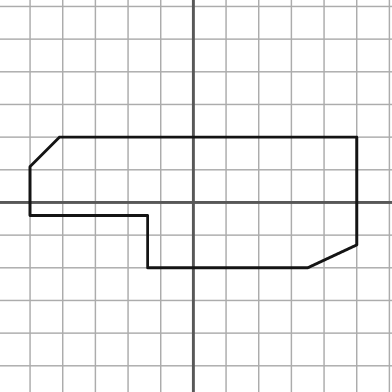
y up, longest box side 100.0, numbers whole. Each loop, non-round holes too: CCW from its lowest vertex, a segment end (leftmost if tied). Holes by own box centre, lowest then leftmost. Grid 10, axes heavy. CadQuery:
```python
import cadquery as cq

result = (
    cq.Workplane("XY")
    .moveTo(-14.0, -20.0)
    .lineTo(35.0, -20.0)
    .lineTo(50.0, -13.0)
    .lineTo(50.0, 20.0)
    .lineTo(-41.0, 20.0)
    .lineTo(-50.0, 11.0)
    .lineTo(-50.0, -4.0)
    .lineTo(-14.0, -4.0)
    .close()
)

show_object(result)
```